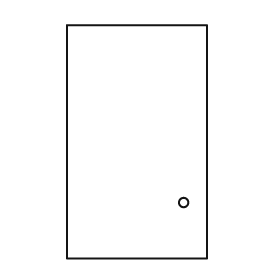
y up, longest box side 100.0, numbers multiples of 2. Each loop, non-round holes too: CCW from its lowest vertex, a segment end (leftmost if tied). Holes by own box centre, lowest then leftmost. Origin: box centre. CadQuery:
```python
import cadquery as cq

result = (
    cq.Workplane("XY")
    .moveTo(-30.0, -50.0)
    .lineTo(30.0, -50.0)
    .lineTo(30.0, 50.0)
    .lineTo(-30.0, 50.0)
    .close()
    .moveTo(20.0, -26.0)
    .circle(2.0)
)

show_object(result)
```